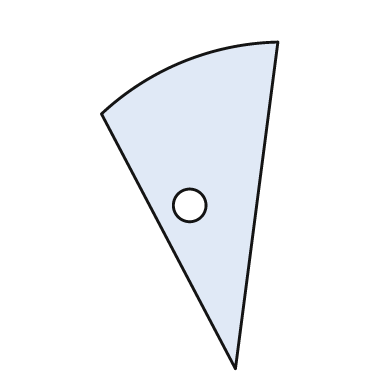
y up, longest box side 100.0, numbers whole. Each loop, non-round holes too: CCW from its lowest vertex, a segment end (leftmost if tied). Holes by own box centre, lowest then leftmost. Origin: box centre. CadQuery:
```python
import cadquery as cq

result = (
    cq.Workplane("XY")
    .moveTo(14.0, -50.0)
    .lineTo(27.0, 50.0)
    .threePointArc((-2.0, 44.0), (-27.0, 28.0))
    .close()
    .moveTo(0.0, 0.0)
    .circle(5.0)
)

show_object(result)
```